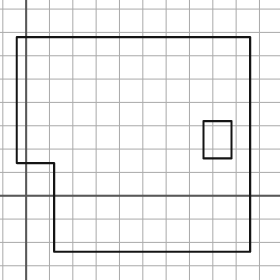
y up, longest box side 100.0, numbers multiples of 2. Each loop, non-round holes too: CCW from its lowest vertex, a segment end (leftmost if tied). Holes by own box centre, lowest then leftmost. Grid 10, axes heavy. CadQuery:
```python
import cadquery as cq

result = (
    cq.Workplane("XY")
    .moveTo(12.0, -24.0)
    .lineTo(96.0, -24.0)
    .lineTo(96.0, 68.0)
    .lineTo(-4.0, 68.0)
    .lineTo(-4.0, 14.0)
    .lineTo(12.0, 14.0)
    .close()
    .moveTo(76.0, 16.0)
    .lineTo(88.0, 16.0)
    .lineTo(88.0, 32.0)
    .lineTo(76.0, 32.0)
    .close()
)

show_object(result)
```